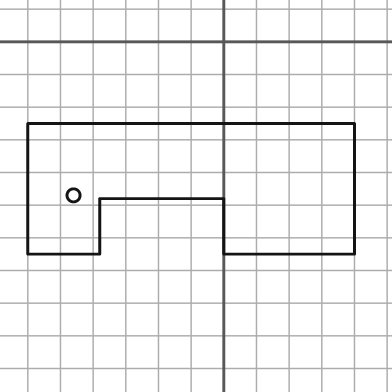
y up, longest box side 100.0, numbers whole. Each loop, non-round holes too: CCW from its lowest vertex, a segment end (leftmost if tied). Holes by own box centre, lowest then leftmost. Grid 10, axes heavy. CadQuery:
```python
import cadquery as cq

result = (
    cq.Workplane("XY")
    .moveTo(-60.0, -65.0)
    .lineTo(-38.0, -65.0)
    .lineTo(-38.0, -48.0)
    .lineTo(0.0, -48.0)
    .lineTo(0.0, -65.0)
    .lineTo(40.0, -65.0)
    .lineTo(40.0, -25.0)
    .lineTo(-60.0, -25.0)
    .close()
    .moveTo(-46.0, -47.0)
    .circle(2.0)
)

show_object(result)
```